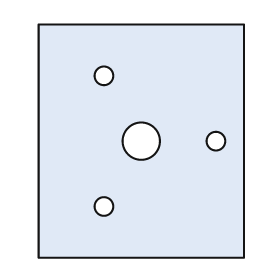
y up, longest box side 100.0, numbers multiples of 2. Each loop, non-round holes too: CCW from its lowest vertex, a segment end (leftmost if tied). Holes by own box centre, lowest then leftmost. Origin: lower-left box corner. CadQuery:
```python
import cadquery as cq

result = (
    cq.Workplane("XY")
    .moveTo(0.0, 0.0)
    .lineTo(88.0, 0.0)
    .lineTo(88.0, 100.0)
    .lineTo(0.0, 100.0)
    .close()
    .moveTo(28.0, 22.0)
    .circle(4.0)
    .moveTo(44.0, 50.0)
    .circle(8.0)
    .moveTo(76.0, 50.0)
    .circle(4.0)
    .moveTo(28.0, 78.0)
    .circle(4.0)
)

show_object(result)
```